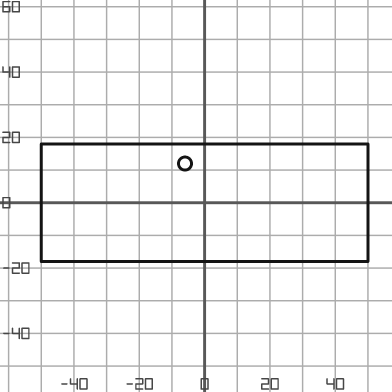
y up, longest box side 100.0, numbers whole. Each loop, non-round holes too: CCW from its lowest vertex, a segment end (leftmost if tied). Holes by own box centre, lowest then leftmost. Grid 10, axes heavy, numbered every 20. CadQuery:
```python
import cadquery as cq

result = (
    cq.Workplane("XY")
    .moveTo(-50.0, -18.0)
    .lineTo(50.0, -18.0)
    .lineTo(50.0, 18.0)
    .lineTo(-50.0, 18.0)
    .close()
    .moveTo(-6.0, 12.0)
    .circle(2.0)
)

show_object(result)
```